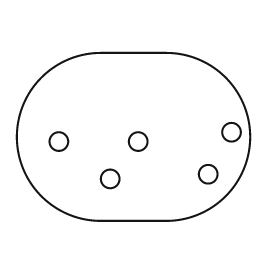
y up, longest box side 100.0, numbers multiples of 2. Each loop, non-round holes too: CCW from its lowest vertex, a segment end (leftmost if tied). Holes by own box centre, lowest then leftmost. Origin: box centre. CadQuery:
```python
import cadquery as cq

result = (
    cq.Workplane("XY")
    .moveTo(-14.0, -36.0)
    .lineTo(14.0, -36.0)
    .threePointArc((50.0, 0.0), (14.0, 36.0))
    .lineTo(-14.0, 36.0)
    .threePointArc((-50.0, 0.0), (-14.0, -36.0))
    .close()
    .moveTo(-10.0, -18.0)
    .circle(4.0)
    .moveTo(32.0, -16.0)
    .circle(4.0)
    .moveTo(-32.0, -2.0)
    .circle(4.0)
    .moveTo(2.0, -2.0)
    .circle(4.0)
    .moveTo(42.0, 2.0)
    .circle(4.0)
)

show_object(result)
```